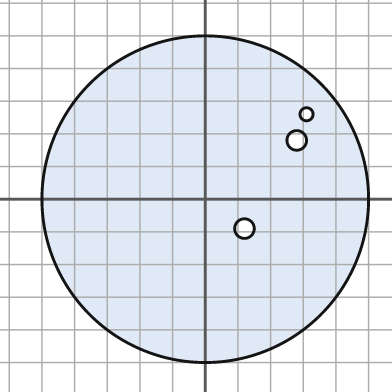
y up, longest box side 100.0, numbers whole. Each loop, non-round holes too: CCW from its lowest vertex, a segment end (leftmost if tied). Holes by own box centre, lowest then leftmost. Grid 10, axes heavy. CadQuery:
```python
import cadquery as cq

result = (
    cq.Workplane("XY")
    .moveTo(0.0, 0.0)
    .circle(50.0)
    .moveTo(12.0, -9.0)
    .circle(3.0)
    .moveTo(28.0, 18.0)
    .circle(3.0)
    .moveTo(31.0, 26.0)
    .circle(2.0)
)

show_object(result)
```